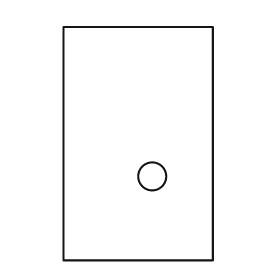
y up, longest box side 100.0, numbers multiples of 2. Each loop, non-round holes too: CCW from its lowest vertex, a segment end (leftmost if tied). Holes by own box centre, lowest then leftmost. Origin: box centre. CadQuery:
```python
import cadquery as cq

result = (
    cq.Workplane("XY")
    .moveTo(-32.0, -50.0)
    .lineTo(32.0, -50.0)
    .lineTo(32.0, 50.0)
    .lineTo(-32.0, 50.0)
    .close()
    .moveTo(6.0, -14.0)
    .circle(6.0)
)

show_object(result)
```